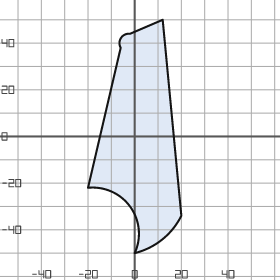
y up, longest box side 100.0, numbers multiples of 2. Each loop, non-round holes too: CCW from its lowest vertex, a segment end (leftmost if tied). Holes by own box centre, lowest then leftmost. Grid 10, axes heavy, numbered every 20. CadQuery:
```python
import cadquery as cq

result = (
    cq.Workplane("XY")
    .moveTo(0.0, -50.0)
    .threePointArc((12.0, -44.0), (20.0, -34.0))
    .lineTo(12.0, 50.0)
    .lineTo(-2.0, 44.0)
    .threePointArc((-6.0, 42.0), (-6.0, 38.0))
    .lineTo(-20.0, -22.0)
    .threePointArc((-2.0, -30.0), (0.0, -50.0))
    .close()
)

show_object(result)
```